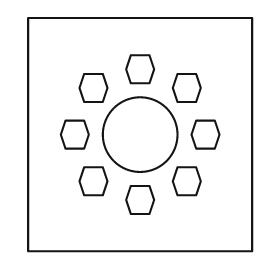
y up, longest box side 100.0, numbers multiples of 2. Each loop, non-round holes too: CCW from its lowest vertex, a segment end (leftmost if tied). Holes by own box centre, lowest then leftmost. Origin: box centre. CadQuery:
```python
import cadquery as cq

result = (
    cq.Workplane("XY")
    .moveTo(-48.0, -50.0)
    .lineTo(48.0, -50.0)
    .lineTo(48.0, 50.0)
    .lineTo(-48.0, 50.0)
    .close()
    .moveTo(-4.0, -34.0)
    .lineTo(4.0, -34.0)
    .lineTo(6.0, -28.0)
    .lineTo(4.0, -22.0)
    .lineTo(-4.0, -22.0)
    .lineTo(-6.0, -28.0)
    .close()
    .moveTo(-24.0, -26.0)
    .lineTo(-16.0, -26.0)
    .lineTo(-14.0, -20.0)
    .lineTo(-16.0, -14.0)
    .lineTo(-24.0, -14.0)
    .lineTo(-26.0, -20.0)
    .close()
    .moveTo(16.0, -26.0)
    .lineTo(24.0, -26.0)
    .lineTo(26.0, -20.0)
    .lineTo(24.0, -14.0)
    .lineTo(16.0, -14.0)
    .lineTo(14.0, -20.0)
    .close()
    .moveTo(-32.0, -6.0)
    .lineTo(-24.0, -6.0)
    .lineTo(-22.0, 0.0)
    .lineTo(-24.0, 6.0)
    .lineTo(-32.0, 6.0)
    .lineTo(-34.0, 0.0)
    .close()
    .moveTo(0.0, 0.0)
    .circle(16.0)
    .moveTo(24.0, -6.0)
    .lineTo(32.0, -6.0)
    .lineTo(34.0, 0.0)
    .lineTo(32.0, 6.0)
    .lineTo(24.0, 6.0)
    .lineTo(22.0, 0.0)
    .close()
    .moveTo(-24.0, 14.0)
    .lineTo(-16.0, 14.0)
    .lineTo(-14.0, 20.0)
    .lineTo(-16.0, 26.0)
    .lineTo(-24.0, 26.0)
    .lineTo(-26.0, 20.0)
    .close()
    .moveTo(16.0, 14.0)
    .lineTo(24.0, 14.0)
    .lineTo(26.0, 20.0)
    .lineTo(24.0, 26.0)
    .lineTo(16.0, 26.0)
    .lineTo(14.0, 20.0)
    .close()
    .moveTo(-4.0, 22.0)
    .lineTo(4.0, 22.0)
    .lineTo(6.0, 28.0)
    .lineTo(4.0, 34.0)
    .lineTo(-4.0, 34.0)
    .lineTo(-6.0, 28.0)
    .close()
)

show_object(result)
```